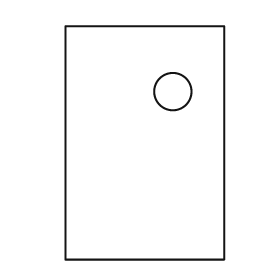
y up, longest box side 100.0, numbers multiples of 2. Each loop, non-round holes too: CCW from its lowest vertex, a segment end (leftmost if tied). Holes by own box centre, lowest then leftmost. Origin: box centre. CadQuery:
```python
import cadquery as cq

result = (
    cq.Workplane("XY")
    .moveTo(-34.0, -50.0)
    .lineTo(34.0, -50.0)
    .lineTo(34.0, 50.0)
    .lineTo(-34.0, 50.0)
    .close()
    .moveTo(12.0, 22.0)
    .circle(8.0)
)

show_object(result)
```